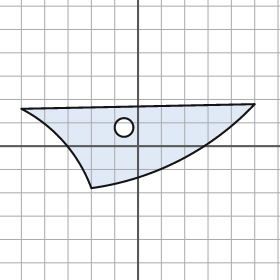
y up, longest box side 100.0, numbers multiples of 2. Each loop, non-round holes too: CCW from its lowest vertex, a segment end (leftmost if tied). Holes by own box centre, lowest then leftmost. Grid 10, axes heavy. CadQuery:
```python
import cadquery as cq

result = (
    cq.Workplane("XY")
    .moveTo(-20.0, -18.0)
    .threePointArc((18.0, -6.0), (50.0, 18.0))
    .lineTo(-50.0, 16.0)
    .threePointArc((-32.0, 2.0), (-20.0, -18.0))
    .close()
    .moveTo(-6.0, 8.0)
    .circle(4.0)
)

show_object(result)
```